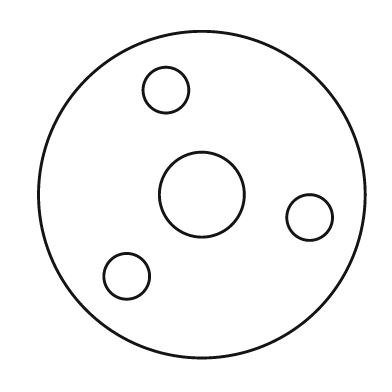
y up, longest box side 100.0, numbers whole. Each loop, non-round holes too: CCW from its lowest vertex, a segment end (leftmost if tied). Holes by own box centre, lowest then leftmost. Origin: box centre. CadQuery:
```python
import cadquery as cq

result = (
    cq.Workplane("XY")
    .moveTo(0.0, 0.0)
    .circle(50.0)
    .moveTo(-23.0, -25.0)
    .circle(7.0)
    .moveTo(33.0, -7.0)
    .circle(7.0)
    .moveTo(0.0, 0.0)
    .circle(13.0)
    .moveTo(-11.0, 32.0)
    .circle(7.0)
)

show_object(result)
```